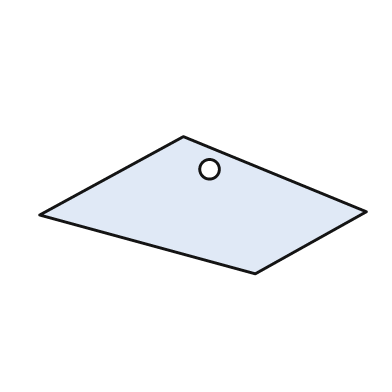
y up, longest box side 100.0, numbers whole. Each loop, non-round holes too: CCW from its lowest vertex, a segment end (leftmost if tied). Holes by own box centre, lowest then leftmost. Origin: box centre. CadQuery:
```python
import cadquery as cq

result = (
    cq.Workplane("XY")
    .moveTo(16.0, -21.0)
    .lineTo(50.0, -2.0)
    .lineTo(-6.0, 21.0)
    .lineTo(-50.0, -3.0)
    .close()
    .moveTo(2.0, 11.0)
    .circle(3.0)
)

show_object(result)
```